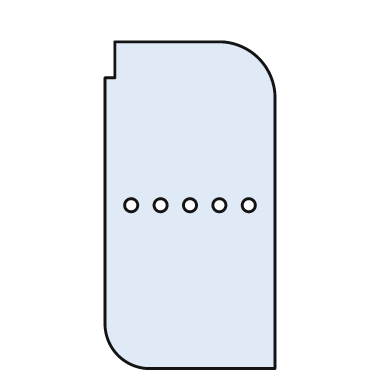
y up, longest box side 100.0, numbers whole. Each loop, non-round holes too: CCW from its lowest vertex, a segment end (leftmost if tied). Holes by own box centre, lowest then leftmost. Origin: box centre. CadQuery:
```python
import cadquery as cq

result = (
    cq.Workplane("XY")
    .moveTo(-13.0, -50.0)
    .lineTo(26.0, -50.0)
    .lineTo(26.0, 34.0)
    .threePointArc((21.0, 45.0), (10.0, 50.0))
    .lineTo(-23.0, 50.0)
    .lineTo(-23.0, 39.0)
    .lineTo(-26.0, 39.0)
    .lineTo(-26.0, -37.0)
    .threePointArc((-22.0, -46.0), (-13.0, -50.0))
    .close()
    .moveTo(-18.0, 0.0)
    .circle(2.0)
    .moveTo(-9.0, 0.0)
    .circle(2.0)
    .moveTo(0.0, 0.0)
    .circle(2.0)
    .moveTo(9.0, 0.0)
    .circle(2.0)
    .moveTo(18.0, 0.0)
    .circle(2.0)
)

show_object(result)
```